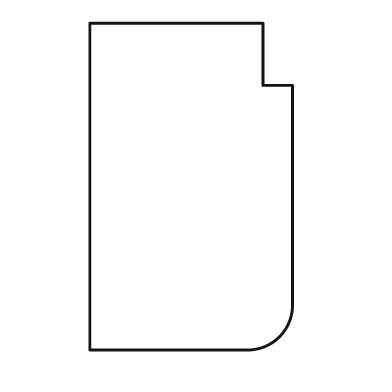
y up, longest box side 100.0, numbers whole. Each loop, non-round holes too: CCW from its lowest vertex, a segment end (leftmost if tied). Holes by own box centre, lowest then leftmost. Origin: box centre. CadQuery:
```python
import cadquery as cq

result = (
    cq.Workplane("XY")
    .moveTo(-31.0, -50.0)
    .lineTo(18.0, -50.0)
    .threePointArc((27.0, -46.0), (31.0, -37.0))
    .lineTo(31.0, 31.0)
    .lineTo(22.0, 31.0)
    .lineTo(22.0, 50.0)
    .lineTo(-31.0, 50.0)
    .close()
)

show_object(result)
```